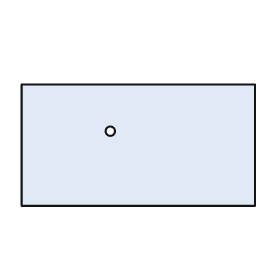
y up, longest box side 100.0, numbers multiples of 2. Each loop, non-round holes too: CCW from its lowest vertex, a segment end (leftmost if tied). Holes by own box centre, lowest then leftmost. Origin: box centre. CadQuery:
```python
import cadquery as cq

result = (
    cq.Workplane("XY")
    .moveTo(-50.0, -26.0)
    .lineTo(50.0, -26.0)
    .lineTo(50.0, 26.0)
    .lineTo(-50.0, 26.0)
    .close()
    .moveTo(-12.0, 6.0)
    .circle(2.0)
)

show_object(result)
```